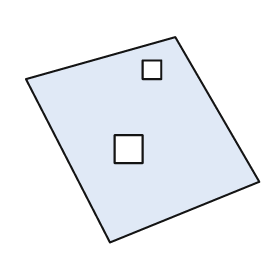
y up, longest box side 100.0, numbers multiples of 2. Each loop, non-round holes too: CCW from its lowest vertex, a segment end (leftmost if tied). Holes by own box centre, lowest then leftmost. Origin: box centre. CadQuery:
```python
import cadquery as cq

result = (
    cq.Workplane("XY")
    .moveTo(-14.0, -44.0)
    .lineTo(50.0, -18.0)
    .lineTo(14.0, 44.0)
    .lineTo(-50.0, 26.0)
    .close()
    .moveTo(-12.0, -10.0)
    .lineTo(0.0, -10.0)
    .lineTo(0.0, 2.0)
    .lineTo(-12.0, 2.0)
    .close()
    .moveTo(0.0, 26.0)
    .lineTo(8.0, 26.0)
    .lineTo(8.0, 34.0)
    .lineTo(0.0, 34.0)
    .close()
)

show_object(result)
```